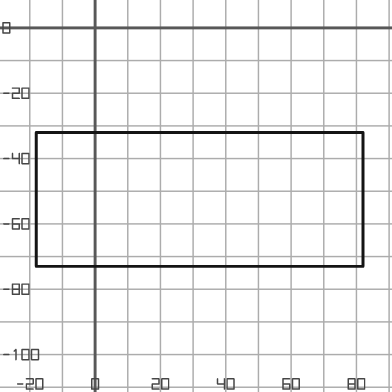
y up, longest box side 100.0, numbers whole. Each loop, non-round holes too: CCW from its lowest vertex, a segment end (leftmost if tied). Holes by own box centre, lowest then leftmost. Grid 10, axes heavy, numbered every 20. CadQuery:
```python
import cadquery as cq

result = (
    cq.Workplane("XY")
    .moveTo(-18.0, -73.0)
    .lineTo(82.0, -73.0)
    .lineTo(82.0, -32.0)
    .lineTo(-18.0, -32.0)
    .close()
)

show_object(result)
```